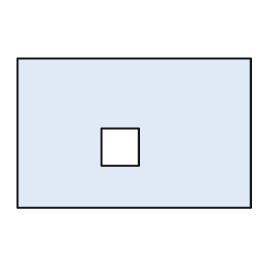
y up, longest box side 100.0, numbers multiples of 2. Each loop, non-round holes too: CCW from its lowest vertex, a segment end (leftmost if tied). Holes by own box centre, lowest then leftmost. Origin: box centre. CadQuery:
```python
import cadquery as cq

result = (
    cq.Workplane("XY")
    .moveTo(-50.0, -32.0)
    .lineTo(50.0, -32.0)
    .lineTo(50.0, 32.0)
    .lineTo(-50.0, 32.0)
    .close()
    .moveTo(-14.0, -14.0)
    .lineTo(2.0, -14.0)
    .lineTo(2.0, 2.0)
    .lineTo(-14.0, 2.0)
    .close()
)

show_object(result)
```